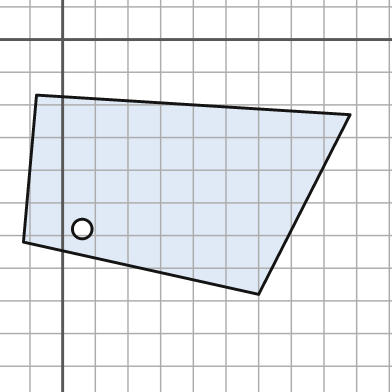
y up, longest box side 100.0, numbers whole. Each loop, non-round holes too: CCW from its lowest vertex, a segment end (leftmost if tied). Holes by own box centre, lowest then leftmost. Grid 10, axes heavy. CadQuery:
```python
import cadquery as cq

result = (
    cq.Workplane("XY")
    .moveTo(60.0, -78.0)
    .lineTo(88.0, -23.0)
    .lineTo(-8.0, -17.0)
    .lineTo(-12.0, -62.0)
    .close()
    .moveTo(6.0, -58.0)
    .circle(3.0)
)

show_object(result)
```